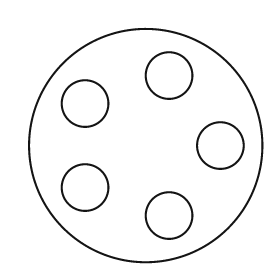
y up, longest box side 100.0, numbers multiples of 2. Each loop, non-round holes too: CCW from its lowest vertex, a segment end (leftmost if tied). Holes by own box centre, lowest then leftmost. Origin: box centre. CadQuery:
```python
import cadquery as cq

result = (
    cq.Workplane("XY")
    .moveTo(0.0, 0.0)
    .circle(50.0)
    .moveTo(10.0, -30.0)
    .circle(10.0)
    .moveTo(-26.0, -18.0)
    .circle(10.0)
    .moveTo(32.0, 0.0)
    .circle(10.0)
    .moveTo(-26.0, 18.0)
    .circle(10.0)
    .moveTo(10.0, 30.0)
    .circle(10.0)
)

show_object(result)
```